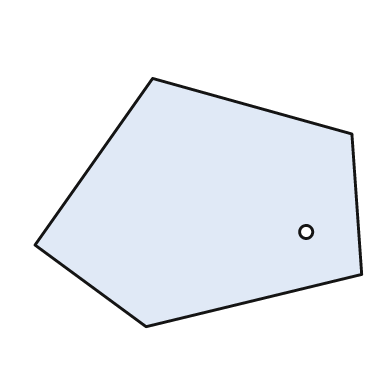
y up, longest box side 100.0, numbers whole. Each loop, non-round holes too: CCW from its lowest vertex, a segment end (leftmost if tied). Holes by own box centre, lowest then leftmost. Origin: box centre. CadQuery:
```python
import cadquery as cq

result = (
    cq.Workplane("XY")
    .moveTo(-16.0, -38.0)
    .lineTo(50.0, -22.0)
    .lineTo(47.0, 21.0)
    .lineTo(-14.0, 38.0)
    .lineTo(-50.0, -13.0)
    .close()
    .moveTo(33.0, -9.0)
    .circle(2.0)
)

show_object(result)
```